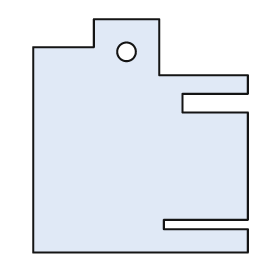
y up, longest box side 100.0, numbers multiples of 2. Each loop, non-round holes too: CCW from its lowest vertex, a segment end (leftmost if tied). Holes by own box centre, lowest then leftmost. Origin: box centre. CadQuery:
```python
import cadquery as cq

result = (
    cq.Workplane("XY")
    .moveTo(-46.0, -50.0)
    .lineTo(46.0, -50.0)
    .lineTo(46.0, -40.0)
    .lineTo(10.0, -40.0)
    .lineTo(10.0, -36.0)
    .lineTo(46.0, -36.0)
    .lineTo(46.0, 10.0)
    .lineTo(18.0, 10.0)
    .lineTo(18.0, 18.0)
    .lineTo(46.0, 18.0)
    .lineTo(46.0, 26.0)
    .lineTo(8.0, 26.0)
    .lineTo(8.0, 50.0)
    .lineTo(-20.0, 50.0)
    .lineTo(-20.0, 38.0)
    .lineTo(-46.0, 38.0)
    .close()
    .moveTo(-6.0, 36.0)
    .circle(4.0)
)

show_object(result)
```